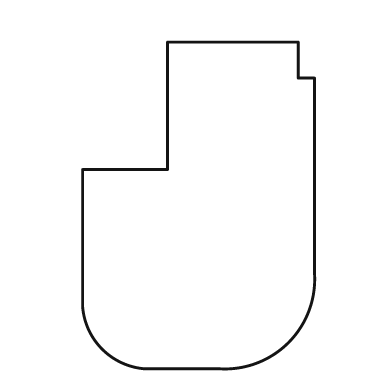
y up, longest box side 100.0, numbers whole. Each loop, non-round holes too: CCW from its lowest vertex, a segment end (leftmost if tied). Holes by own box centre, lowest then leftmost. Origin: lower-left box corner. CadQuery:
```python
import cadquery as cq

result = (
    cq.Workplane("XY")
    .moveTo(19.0, 0.0)
    .lineTo(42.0, 0.0)
    .threePointArc((63.0, 8.0), (71.0, 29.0))
    .lineTo(71.0, 89.0)
    .lineTo(66.0, 89.0)
    .lineTo(66.0, 100.0)
    .lineTo(26.0, 100.0)
    .lineTo(26.0, 61.0)
    .lineTo(0.0, 61.0)
    .lineTo(0.0, 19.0)
    .threePointArc((6.0, 6.0), (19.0, 0.0))
    .close()
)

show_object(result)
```